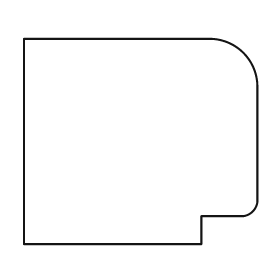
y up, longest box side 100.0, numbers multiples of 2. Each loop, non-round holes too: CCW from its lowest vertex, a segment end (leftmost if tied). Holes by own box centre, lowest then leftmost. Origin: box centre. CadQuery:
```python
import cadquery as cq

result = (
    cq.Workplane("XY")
    .moveTo(-50.0, -44.0)
    .lineTo(26.0, -44.0)
    .lineTo(26.0, -32.0)
    .lineTo(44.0, -32.0)
    .threePointArc((48.0, -30.0), (50.0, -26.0))
    .lineTo(50.0, 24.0)
    .threePointArc((44.0, 38.0), (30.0, 44.0))
    .lineTo(-50.0, 44.0)
    .close()
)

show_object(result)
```